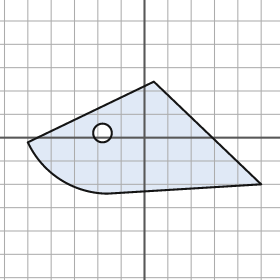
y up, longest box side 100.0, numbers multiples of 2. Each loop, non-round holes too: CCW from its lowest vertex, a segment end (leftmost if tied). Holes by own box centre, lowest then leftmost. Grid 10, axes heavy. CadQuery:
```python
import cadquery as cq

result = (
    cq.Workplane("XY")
    .moveTo(-16.0, -24.0)
    .lineTo(50.0, -20.0)
    .lineTo(4.0, 24.0)
    .lineTo(-50.0, -2.0)
    .threePointArc((-36.0, -18.0), (-16.0, -24.0))
    .close()
    .moveTo(-18.0, 2.0)
    .circle(4.0)
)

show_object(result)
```